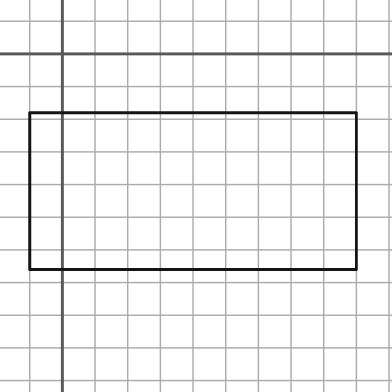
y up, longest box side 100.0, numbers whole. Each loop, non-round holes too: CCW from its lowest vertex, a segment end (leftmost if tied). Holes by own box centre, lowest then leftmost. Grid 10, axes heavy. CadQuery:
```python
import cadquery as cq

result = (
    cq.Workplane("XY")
    .moveTo(-10.0, -66.0)
    .lineTo(90.0, -66.0)
    .lineTo(90.0, -18.0)
    .lineTo(-10.0, -18.0)
    .close()
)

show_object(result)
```